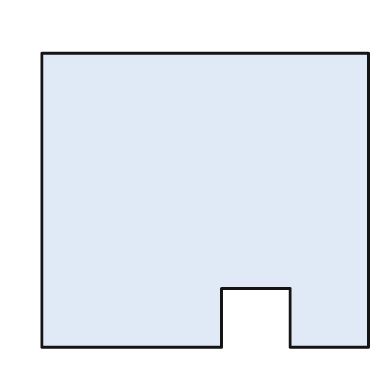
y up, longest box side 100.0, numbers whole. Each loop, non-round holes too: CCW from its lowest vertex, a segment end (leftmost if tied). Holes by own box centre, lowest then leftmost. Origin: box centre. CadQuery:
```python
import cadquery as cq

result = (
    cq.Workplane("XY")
    .moveTo(-50.0, -45.0)
    .lineTo(5.0, -45.0)
    .lineTo(5.0, -27.0)
    .lineTo(26.0, -27.0)
    .lineTo(26.0, -45.0)
    .lineTo(50.0, -45.0)
    .lineTo(50.0, 45.0)
    .lineTo(-50.0, 45.0)
    .close()
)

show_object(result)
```